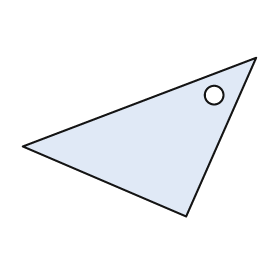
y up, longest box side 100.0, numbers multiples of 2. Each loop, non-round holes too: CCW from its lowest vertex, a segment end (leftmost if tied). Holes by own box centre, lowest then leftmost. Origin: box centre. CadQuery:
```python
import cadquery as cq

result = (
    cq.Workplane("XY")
    .moveTo(20.0, -34.0)
    .lineTo(50.0, 34.0)
    .lineTo(-50.0, -4.0)
    .close()
    .moveTo(32.0, 18.0)
    .circle(4.0)
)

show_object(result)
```